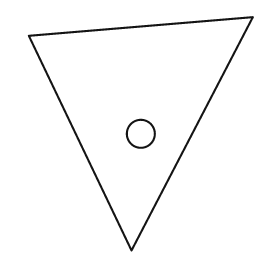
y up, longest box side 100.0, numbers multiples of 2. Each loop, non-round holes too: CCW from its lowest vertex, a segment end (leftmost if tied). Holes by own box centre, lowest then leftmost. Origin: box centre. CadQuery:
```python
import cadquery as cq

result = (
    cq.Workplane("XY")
    .moveTo(-4.0, -50.0)
    .lineTo(48.0, 50.0)
    .lineTo(-48.0, 42.0)
    .close()
    .moveTo(0.0, 0.0)
    .circle(6.0)
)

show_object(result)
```